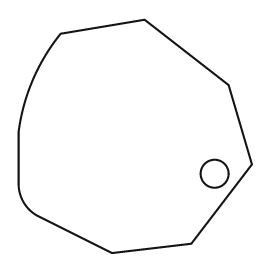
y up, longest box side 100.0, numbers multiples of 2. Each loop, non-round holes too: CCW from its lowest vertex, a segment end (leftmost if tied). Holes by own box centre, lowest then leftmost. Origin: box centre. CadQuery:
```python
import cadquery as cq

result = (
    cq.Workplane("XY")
    .moveTo(-10.0, -50.0)
    .lineTo(24.0, -46.0)
    .lineTo(50.0, -12.0)
    .lineTo(40.0, 22.0)
    .lineTo(4.0, 50.0)
    .lineTo(-32.0, 44.0)
    .threePointArc((-44.0, 24.0), (-50.0, 2.0))
    .lineTo(-50.0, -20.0)
    .threePointArc((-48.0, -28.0), (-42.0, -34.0))
    .close()
    .moveTo(34.0, -16.0)
    .circle(6.0)
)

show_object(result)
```